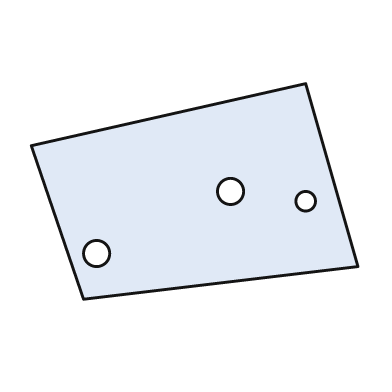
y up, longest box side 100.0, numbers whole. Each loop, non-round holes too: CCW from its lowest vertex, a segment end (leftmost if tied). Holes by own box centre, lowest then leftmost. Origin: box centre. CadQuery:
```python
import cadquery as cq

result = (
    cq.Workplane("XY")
    .moveTo(-34.0, -33.0)
    .lineTo(50.0, -23.0)
    .lineTo(34.0, 33.0)
    .lineTo(-50.0, 14.0)
    .close()
    .moveTo(-30.0, -19.0)
    .circle(4.0)
    .moveTo(34.0, -3.0)
    .circle(3.0)
    .moveTo(11.0, 0.0)
    .circle(4.0)
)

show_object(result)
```